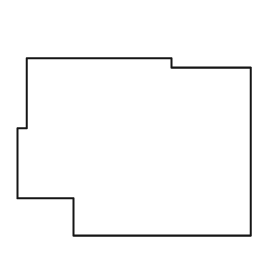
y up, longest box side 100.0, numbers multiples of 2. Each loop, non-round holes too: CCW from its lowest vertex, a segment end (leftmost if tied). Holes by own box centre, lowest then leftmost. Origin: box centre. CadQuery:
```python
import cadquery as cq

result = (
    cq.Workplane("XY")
    .moveTo(-26.0, -38.0)
    .lineTo(50.0, -38.0)
    .lineTo(50.0, 34.0)
    .lineTo(16.0, 34.0)
    .lineTo(16.0, 38.0)
    .lineTo(-46.0, 38.0)
    .lineTo(-46.0, 8.0)
    .lineTo(-50.0, 8.0)
    .lineTo(-50.0, -22.0)
    .lineTo(-26.0, -22.0)
    .close()
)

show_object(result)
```